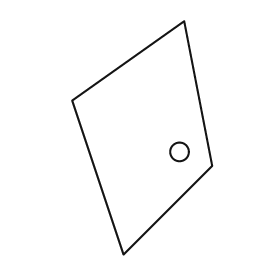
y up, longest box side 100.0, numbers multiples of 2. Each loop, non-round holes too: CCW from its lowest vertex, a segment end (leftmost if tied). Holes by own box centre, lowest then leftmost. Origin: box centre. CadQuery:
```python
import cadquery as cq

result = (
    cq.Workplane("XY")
    .moveTo(-8.0, -50.0)
    .lineTo(30.0, -12.0)
    .lineTo(18.0, 50.0)
    .lineTo(-30.0, 16.0)
    .close()
    .moveTo(16.0, -6.0)
    .circle(4.0)
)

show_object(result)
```